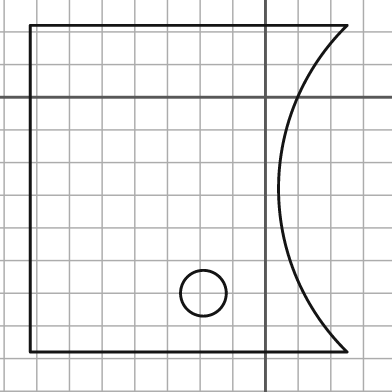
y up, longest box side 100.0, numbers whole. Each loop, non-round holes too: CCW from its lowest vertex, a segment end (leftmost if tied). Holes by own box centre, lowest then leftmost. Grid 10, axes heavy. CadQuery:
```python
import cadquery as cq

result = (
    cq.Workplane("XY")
    .moveTo(-72.0, -78.0)
    .lineTo(25.0, -78.0)
    .threePointArc((4.0, -28.0), (25.0, 22.0))
    .lineTo(-72.0, 22.0)
    .close()
    .moveTo(-19.0, -60.0)
    .circle(7.0)
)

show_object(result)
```